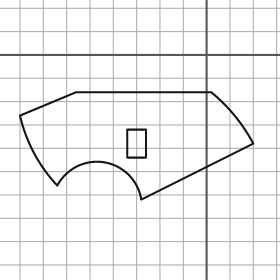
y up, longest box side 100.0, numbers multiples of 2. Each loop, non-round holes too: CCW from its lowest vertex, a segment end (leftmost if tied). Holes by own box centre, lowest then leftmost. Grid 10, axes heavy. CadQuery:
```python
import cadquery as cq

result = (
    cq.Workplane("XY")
    .moveTo(-28.0, -62.0)
    .lineTo(20.0, -38.0)
    .threePointArc((12.0, -26.0), (2.0, -16.0))
    .lineTo(-56.0, -16.0)
    .lineTo(-80.0, -26.0)
    .threePointArc((-74.0, -42.0), (-64.0, -56.0))
    .threePointArc((-44.0, -46.0), (-28.0, -62.0))
    .close()
    .moveTo(-34.0, -44.0)
    .lineTo(-26.0, -44.0)
    .lineTo(-26.0, -32.0)
    .lineTo(-34.0, -32.0)
    .close()
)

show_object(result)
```